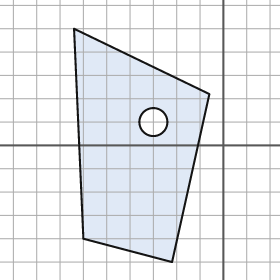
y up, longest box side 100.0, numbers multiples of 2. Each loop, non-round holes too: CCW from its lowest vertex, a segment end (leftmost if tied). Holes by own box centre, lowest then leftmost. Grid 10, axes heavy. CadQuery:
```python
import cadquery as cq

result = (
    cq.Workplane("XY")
    .moveTo(-22.0, -50.0)
    .lineTo(-6.0, 22.0)
    .lineTo(-64.0, 50.0)
    .lineTo(-60.0, -40.0)
    .close()
    .moveTo(-30.0, 10.0)
    .circle(6.0)
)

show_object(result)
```